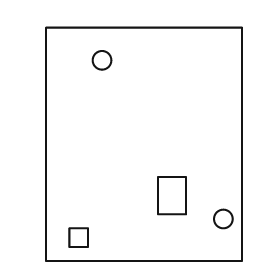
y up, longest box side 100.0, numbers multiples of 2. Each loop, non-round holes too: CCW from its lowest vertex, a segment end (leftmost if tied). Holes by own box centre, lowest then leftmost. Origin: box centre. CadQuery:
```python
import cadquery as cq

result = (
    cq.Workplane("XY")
    .moveTo(-42.0, -50.0)
    .lineTo(42.0, -50.0)
    .lineTo(42.0, 50.0)
    .lineTo(-42.0, 50.0)
    .close()
    .moveTo(-32.0, -44.0)
    .lineTo(-24.0, -44.0)
    .lineTo(-24.0, -36.0)
    .lineTo(-32.0, -36.0)
    .close()
    .moveTo(34.0, -32.0)
    .circle(4.0)
    .moveTo(6.0, -30.0)
    .lineTo(18.0, -30.0)
    .lineTo(18.0, -14.0)
    .lineTo(6.0, -14.0)
    .close()
    .moveTo(-18.0, 36.0)
    .circle(4.0)
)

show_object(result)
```